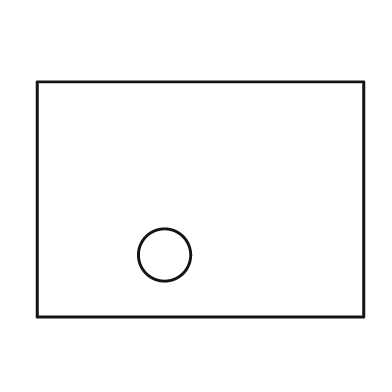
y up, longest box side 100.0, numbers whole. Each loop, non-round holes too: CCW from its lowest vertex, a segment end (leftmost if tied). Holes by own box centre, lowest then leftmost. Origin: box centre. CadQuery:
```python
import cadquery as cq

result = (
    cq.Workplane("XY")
    .moveTo(-50.0, -36.0)
    .lineTo(50.0, -36.0)
    .lineTo(50.0, 36.0)
    .lineTo(-50.0, 36.0)
    .close()
    .moveTo(-11.0, -17.0)
    .circle(8.0)
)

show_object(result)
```